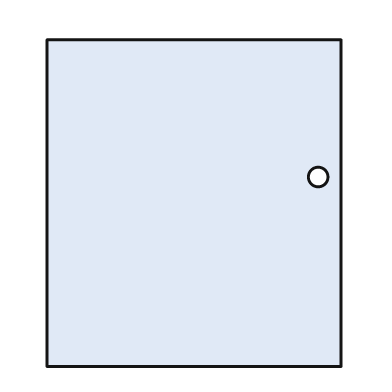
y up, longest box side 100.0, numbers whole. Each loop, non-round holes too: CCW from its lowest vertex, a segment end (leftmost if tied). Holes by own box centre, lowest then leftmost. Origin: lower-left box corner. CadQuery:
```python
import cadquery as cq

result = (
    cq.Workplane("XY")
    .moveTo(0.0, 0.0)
    .lineTo(90.0, 0.0)
    .lineTo(90.0, 100.0)
    .lineTo(0.0, 100.0)
    .close()
    .moveTo(83.0, 58.0)
    .circle(3.0)
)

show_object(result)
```